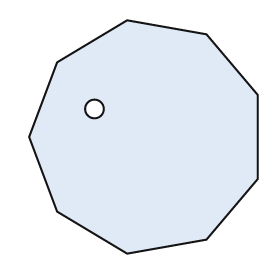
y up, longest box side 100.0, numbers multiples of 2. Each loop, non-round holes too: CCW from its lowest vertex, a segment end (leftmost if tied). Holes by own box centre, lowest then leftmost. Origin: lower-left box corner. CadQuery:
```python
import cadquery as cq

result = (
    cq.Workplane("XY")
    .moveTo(42.0, 0.0)
    .lineTo(76.0, 6.0)
    .lineTo(98.0, 32.0)
    .lineTo(98.0, 68.0)
    .lineTo(76.0, 94.0)
    .lineTo(42.0, 100.0)
    .lineTo(12.0, 82.0)
    .lineTo(0.0, 50.0)
    .lineTo(12.0, 18.0)
    .close()
    .moveTo(28.0, 62.0)
    .circle(4.0)
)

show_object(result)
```